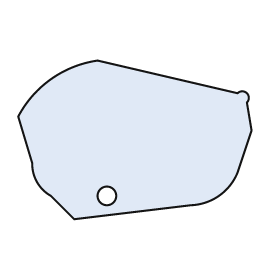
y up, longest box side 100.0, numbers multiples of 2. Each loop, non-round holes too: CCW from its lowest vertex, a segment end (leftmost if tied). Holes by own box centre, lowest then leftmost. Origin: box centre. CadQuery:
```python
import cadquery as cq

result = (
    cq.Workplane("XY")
    .moveTo(-26.0, -34.0)
    .lineTo(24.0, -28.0)
    .threePointArc((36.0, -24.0), (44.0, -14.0))
    .lineTo(50.0, 4.0)
    .lineTo(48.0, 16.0)
    .threePointArc((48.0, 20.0), (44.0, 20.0))
    .lineTo(-16.0, 34.0)
    .threePointArc((-36.0, 26.0), (-50.0, 10.0))
    .lineTo(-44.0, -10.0)
    .threePointArc((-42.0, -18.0), (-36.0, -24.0))
    .close()
    .moveTo(-12.0, -24.0)
    .circle(4.0)
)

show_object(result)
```